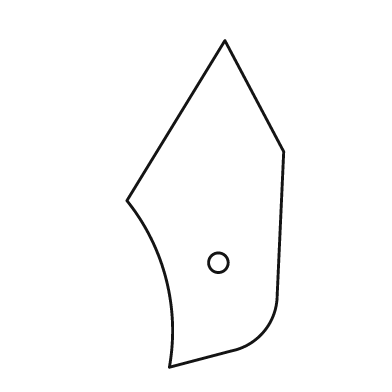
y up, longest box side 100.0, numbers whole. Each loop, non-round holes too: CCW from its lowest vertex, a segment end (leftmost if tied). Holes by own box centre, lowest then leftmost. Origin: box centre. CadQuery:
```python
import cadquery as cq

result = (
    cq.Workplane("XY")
    .moveTo(-11.0, -50.0)
    .lineTo(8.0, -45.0)
    .threePointArc((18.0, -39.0), (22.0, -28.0))
    .lineTo(24.0, 16.0)
    .lineTo(6.0, 50.0)
    .lineTo(-24.0, 1.0)
    .threePointArc((-12.0, -23.0), (-11.0, -50.0))
    .close()
    .moveTo(4.0, -18.0)
    .circle(3.0)
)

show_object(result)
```